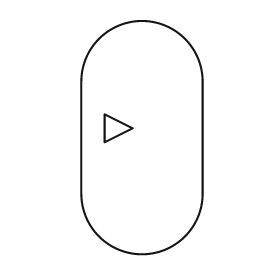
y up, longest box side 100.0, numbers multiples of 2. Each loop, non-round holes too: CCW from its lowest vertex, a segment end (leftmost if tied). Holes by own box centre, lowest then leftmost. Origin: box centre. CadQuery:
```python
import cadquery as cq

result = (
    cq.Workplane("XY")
    .moveTo(-26.0, -24.0)
    .threePointArc((0.0, -50.0), (26.0, -24.0))
    .lineTo(26.0, 24.0)
    .threePointArc((0.0, 50.0), (-26.0, 24.0))
    .close()
    .moveTo(-16.0, -2.0)
    .lineTo(-4.0, 4.0)
    .lineTo(-16.0, 10.0)
    .close()
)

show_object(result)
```